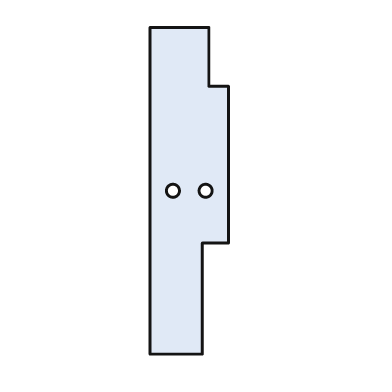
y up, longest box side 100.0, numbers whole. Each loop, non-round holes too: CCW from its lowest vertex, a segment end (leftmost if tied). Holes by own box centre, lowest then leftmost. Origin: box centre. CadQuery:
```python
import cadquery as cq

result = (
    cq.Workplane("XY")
    .moveTo(-12.0, -50.0)
    .lineTo(4.0, -50.0)
    .lineTo(4.0, -16.0)
    .lineTo(12.0, -16.0)
    .lineTo(12.0, 32.0)
    .lineTo(6.0, 32.0)
    .lineTo(6.0, 50.0)
    .lineTo(-12.0, 50.0)
    .close()
    .moveTo(-5.0, 0.0)
    .circle(2.0)
    .moveTo(5.0, 0.0)
    .circle(2.0)
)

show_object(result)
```